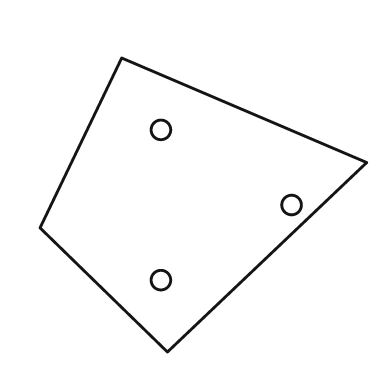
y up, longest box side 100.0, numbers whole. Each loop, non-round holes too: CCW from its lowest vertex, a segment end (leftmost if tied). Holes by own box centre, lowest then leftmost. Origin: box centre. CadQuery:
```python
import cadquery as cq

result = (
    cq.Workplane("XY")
    .moveTo(-11.0, -45.0)
    .lineTo(50.0, 13.0)
    .lineTo(-25.0, 45.0)
    .lineTo(-50.0, -7.0)
    .close()
    .moveTo(-13.0, -23.0)
    .circle(3.0)
    .moveTo(27.0, 0.0)
    .circle(3.0)
    .moveTo(-13.0, 23.0)
    .circle(3.0)
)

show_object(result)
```